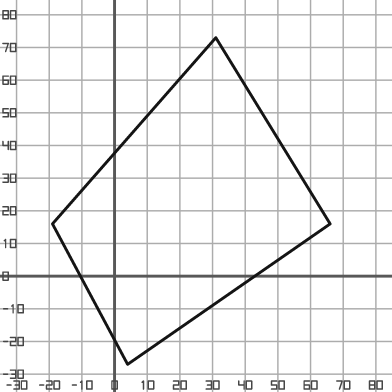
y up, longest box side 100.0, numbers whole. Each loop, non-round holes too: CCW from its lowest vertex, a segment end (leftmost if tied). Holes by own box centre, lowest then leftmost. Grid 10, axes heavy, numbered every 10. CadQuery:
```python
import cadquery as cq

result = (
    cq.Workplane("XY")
    .moveTo(4.0, -27.0)
    .lineTo(66.0, 16.0)
    .lineTo(31.0, 73.0)
    .lineTo(-19.0, 16.0)
    .close()
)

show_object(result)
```